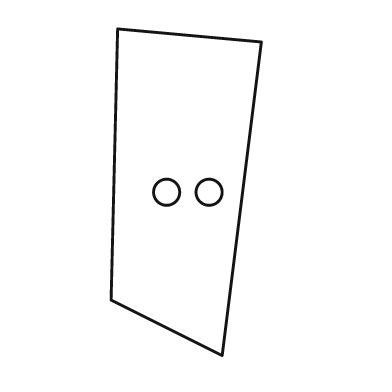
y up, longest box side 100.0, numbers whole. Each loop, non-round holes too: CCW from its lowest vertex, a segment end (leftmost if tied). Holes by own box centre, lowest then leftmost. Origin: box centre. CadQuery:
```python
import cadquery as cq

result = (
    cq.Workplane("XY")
    .moveTo(11.0, -50.0)
    .lineTo(23.0, 46.0)
    .lineTo(-21.0, 50.0)
    .lineTo(-23.0, -33.0)
    .close()
    .moveTo(-6.0, 0.0)
    .circle(4.0)
    .moveTo(7.0, 0.0)
    .circle(4.0)
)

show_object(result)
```